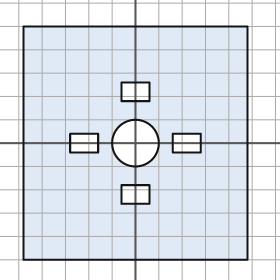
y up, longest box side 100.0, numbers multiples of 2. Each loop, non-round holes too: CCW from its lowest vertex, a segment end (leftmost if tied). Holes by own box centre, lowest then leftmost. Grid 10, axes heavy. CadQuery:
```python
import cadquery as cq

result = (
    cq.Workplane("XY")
    .moveTo(-48.0, -50.0)
    .lineTo(48.0, -50.0)
    .lineTo(48.0, 50.0)
    .lineTo(-48.0, 50.0)
    .close()
    .moveTo(-6.0, -26.0)
    .lineTo(6.0, -26.0)
    .lineTo(6.0, -18.0)
    .lineTo(-6.0, -18.0)
    .close()
    .moveTo(-28.0, -4.0)
    .lineTo(-16.0, -4.0)
    .lineTo(-16.0, 4.0)
    .lineTo(-28.0, 4.0)
    .close()
    .moveTo(0.0, 0.0)
    .circle(10.0)
    .moveTo(16.0, -4.0)
    .lineTo(28.0, -4.0)
    .lineTo(28.0, 4.0)
    .lineTo(16.0, 4.0)
    .close()
    .moveTo(-6.0, 18.0)
    .lineTo(6.0, 18.0)
    .lineTo(6.0, 26.0)
    .lineTo(-6.0, 26.0)
    .close()
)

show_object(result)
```